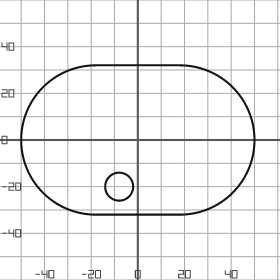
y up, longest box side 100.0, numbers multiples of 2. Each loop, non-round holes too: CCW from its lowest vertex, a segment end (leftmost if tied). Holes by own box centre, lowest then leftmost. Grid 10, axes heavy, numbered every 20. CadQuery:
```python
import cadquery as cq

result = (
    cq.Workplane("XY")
    .moveTo(-18.0, -32.0)
    .lineTo(18.0, -32.0)
    .threePointArc((50.0, 0.0), (18.0, 32.0))
    .lineTo(-18.0, 32.0)
    .threePointArc((-50.0, 0.0), (-18.0, -32.0))
    .close()
    .moveTo(-8.0, -20.0)
    .circle(6.0)
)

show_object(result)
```